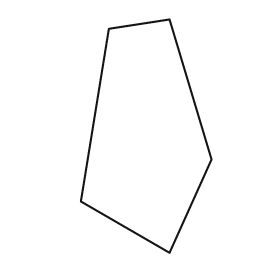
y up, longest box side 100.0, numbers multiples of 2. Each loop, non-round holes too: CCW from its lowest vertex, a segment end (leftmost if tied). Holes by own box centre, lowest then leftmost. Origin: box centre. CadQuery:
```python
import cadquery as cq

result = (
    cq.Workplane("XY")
    .moveTo(10.0, -50.0)
    .lineTo(28.0, -10.0)
    .lineTo(10.0, 50.0)
    .lineTo(-16.0, 46.0)
    .lineTo(-28.0, -28.0)
    .close()
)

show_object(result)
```